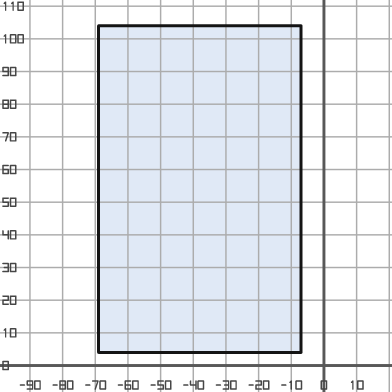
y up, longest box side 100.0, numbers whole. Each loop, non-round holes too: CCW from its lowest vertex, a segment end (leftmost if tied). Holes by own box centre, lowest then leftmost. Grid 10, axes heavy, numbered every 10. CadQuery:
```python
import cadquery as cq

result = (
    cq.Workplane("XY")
    .moveTo(-69.0, 4.0)
    .lineTo(-7.0, 4.0)
    .lineTo(-7.0, 104.0)
    .lineTo(-69.0, 104.0)
    .close()
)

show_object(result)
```